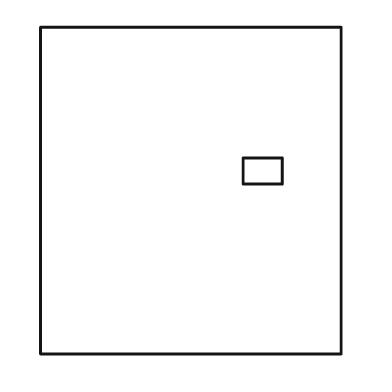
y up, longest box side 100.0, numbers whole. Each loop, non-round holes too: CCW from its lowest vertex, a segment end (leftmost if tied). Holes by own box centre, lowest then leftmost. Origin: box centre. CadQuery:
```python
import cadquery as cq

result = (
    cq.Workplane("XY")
    .moveTo(-46.0, -50.0)
    .lineTo(46.0, -50.0)
    .lineTo(46.0, 50.0)
    .lineTo(-46.0, 50.0)
    .close()
    .moveTo(16.0, 2.0)
    .lineTo(28.0, 2.0)
    .lineTo(28.0, 10.0)
    .lineTo(16.0, 10.0)
    .close()
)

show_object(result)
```